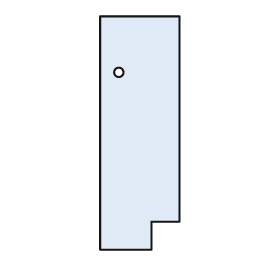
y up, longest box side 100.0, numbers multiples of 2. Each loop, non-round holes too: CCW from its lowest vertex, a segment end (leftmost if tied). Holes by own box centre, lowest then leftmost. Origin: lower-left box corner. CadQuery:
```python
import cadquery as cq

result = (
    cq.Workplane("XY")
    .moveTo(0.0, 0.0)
    .lineTo(22.0, 0.0)
    .lineTo(22.0, 12.0)
    .lineTo(34.0, 12.0)
    .lineTo(34.0, 100.0)
    .lineTo(0.0, 100.0)
    .close()
    .moveTo(8.0, 76.0)
    .circle(2.0)
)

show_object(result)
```